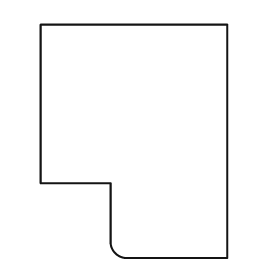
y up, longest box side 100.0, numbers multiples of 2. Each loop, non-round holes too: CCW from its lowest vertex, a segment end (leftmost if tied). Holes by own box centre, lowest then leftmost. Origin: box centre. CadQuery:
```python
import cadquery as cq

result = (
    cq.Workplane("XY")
    .moveTo(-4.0, -50.0)
    .lineTo(40.0, -50.0)
    .lineTo(40.0, 50.0)
    .lineTo(-40.0, 50.0)
    .lineTo(-40.0, -18.0)
    .lineTo(-10.0, -18.0)
    .lineTo(-10.0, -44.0)
    .threePointArc((-8.0, -48.0), (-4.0, -50.0))
    .close()
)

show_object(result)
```